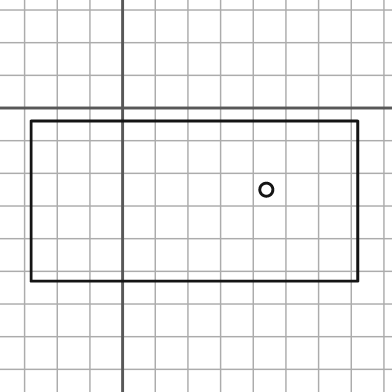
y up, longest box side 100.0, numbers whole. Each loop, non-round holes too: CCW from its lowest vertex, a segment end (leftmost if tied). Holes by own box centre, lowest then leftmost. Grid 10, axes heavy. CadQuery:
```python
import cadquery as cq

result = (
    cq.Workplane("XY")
    .moveTo(-28.0, -53.0)
    .lineTo(72.0, -53.0)
    .lineTo(72.0, -4.0)
    .lineTo(-28.0, -4.0)
    .close()
    .moveTo(44.0, -25.0)
    .circle(2.0)
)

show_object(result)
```